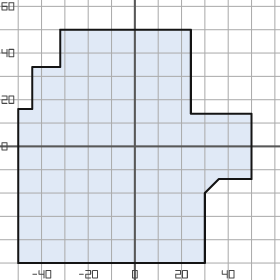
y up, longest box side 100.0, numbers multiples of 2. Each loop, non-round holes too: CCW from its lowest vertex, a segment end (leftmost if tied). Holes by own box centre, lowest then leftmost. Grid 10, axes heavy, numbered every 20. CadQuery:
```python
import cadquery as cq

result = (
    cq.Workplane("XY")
    .moveTo(-50.0, -50.0)
    .lineTo(30.0, -50.0)
    .lineTo(30.0, -20.0)
    .lineTo(36.0, -14.0)
    .lineTo(50.0, -14.0)
    .lineTo(50.0, 14.0)
    .lineTo(24.0, 14.0)
    .lineTo(24.0, 50.0)
    .lineTo(-32.0, 50.0)
    .lineTo(-32.0, 34.0)
    .lineTo(-44.0, 34.0)
    .lineTo(-44.0, 16.0)
    .lineTo(-50.0, 16.0)
    .close()
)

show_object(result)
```